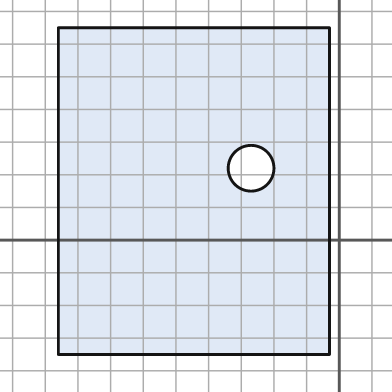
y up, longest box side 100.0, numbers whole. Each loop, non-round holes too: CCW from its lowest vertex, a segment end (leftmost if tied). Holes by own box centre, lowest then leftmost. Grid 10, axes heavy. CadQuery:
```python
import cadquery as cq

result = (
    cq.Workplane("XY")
    .moveTo(-86.0, -35.0)
    .lineTo(-3.0, -35.0)
    .lineTo(-3.0, 65.0)
    .lineTo(-86.0, 65.0)
    .close()
    .moveTo(-27.0, 22.0)
    .circle(7.0)
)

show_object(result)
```